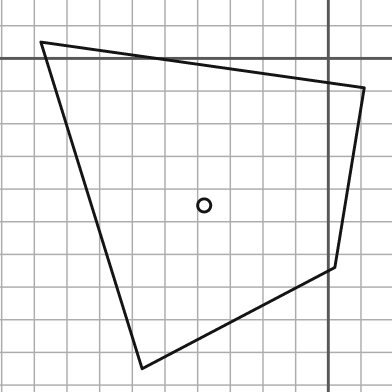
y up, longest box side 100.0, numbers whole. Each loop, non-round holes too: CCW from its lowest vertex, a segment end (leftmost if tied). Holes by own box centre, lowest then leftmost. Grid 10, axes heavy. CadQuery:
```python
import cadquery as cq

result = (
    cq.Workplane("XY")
    .moveTo(-57.0, -95.0)
    .lineTo(2.0, -64.0)
    .lineTo(11.0, -9.0)
    .lineTo(-88.0, 5.0)
    .close()
    .moveTo(-38.0, -45.0)
    .circle(2.0)
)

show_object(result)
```